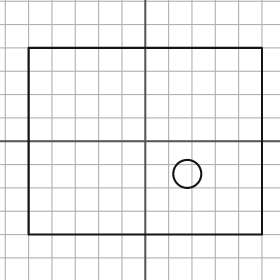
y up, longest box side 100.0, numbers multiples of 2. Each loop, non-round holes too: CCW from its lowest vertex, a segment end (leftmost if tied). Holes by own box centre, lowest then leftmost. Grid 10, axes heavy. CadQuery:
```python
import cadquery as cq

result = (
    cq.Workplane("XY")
    .moveTo(-50.0, -40.0)
    .lineTo(50.0, -40.0)
    .lineTo(50.0, 40.0)
    .lineTo(-50.0, 40.0)
    .close()
    .moveTo(18.0, -14.0)
    .circle(6.0)
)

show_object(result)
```